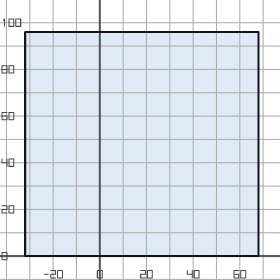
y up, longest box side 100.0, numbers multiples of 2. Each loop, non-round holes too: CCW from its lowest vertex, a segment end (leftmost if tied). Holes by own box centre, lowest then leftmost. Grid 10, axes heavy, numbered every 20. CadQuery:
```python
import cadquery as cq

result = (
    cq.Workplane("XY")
    .moveTo(-32.0, 0.0)
    .lineTo(68.0, 0.0)
    .lineTo(68.0, 96.0)
    .lineTo(-32.0, 96.0)
    .close()
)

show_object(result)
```